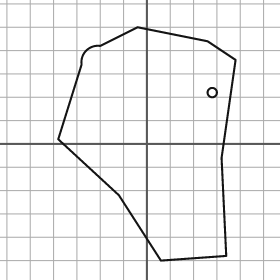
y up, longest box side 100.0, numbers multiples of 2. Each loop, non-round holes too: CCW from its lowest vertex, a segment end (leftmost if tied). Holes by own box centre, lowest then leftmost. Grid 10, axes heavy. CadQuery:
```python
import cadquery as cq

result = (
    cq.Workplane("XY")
    .moveTo(6.0, -50.0)
    .lineTo(34.0, -48.0)
    .lineTo(32.0, -6.0)
    .lineTo(38.0, 36.0)
    .lineTo(26.0, 44.0)
    .lineTo(-4.0, 50.0)
    .lineTo(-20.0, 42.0)
    .threePointArc((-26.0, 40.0), (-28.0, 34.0))
    .lineTo(-38.0, 2.0)
    .lineTo(-12.0, -22.0)
    .close()
    .moveTo(28.0, 22.0)
    .circle(2.0)
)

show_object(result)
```